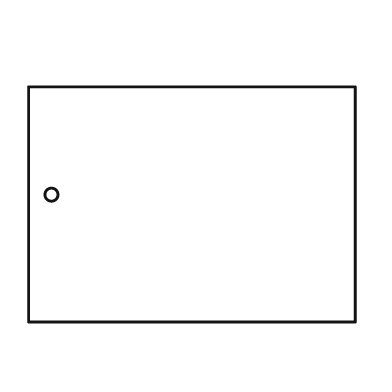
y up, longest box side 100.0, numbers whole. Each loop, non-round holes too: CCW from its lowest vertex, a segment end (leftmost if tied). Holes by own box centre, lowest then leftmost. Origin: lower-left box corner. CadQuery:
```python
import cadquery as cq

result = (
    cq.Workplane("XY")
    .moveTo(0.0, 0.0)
    .lineTo(100.0, 0.0)
    .lineTo(100.0, 72.0)
    .lineTo(0.0, 72.0)
    .close()
    .moveTo(7.0, 39.0)
    .circle(2.0)
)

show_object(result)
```